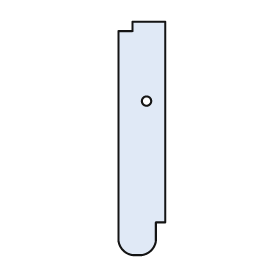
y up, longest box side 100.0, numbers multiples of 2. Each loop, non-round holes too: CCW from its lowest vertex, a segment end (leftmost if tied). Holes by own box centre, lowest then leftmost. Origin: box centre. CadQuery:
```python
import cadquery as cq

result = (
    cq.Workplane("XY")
    .moveTo(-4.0, -50.0)
    .lineTo(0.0, -50.0)
    .threePointArc((4.0, -48.0), (6.0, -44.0))
    .lineTo(6.0, -36.0)
    .lineTo(10.0, -36.0)
    .lineTo(10.0, 50.0)
    .lineTo(-4.0, 50.0)
    .lineTo(-4.0, 46.0)
    .lineTo(-10.0, 46.0)
    .lineTo(-10.0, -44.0)
    .threePointArc((-8.0, -48.0), (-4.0, -50.0))
    .close()
    .moveTo(2.0, 16.0)
    .circle(2.0)
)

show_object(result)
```